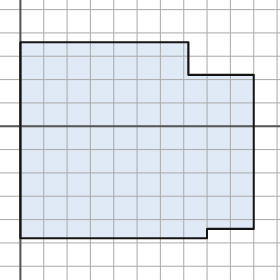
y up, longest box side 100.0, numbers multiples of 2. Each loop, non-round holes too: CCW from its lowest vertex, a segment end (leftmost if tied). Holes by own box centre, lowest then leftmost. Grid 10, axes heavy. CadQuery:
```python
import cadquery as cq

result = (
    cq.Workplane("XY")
    .moveTo(0.0, -48.0)
    .lineTo(80.0, -48.0)
    .lineTo(80.0, -44.0)
    .lineTo(100.0, -44.0)
    .lineTo(100.0, 22.0)
    .lineTo(72.0, 22.0)
    .lineTo(72.0, 36.0)
    .lineTo(0.0, 36.0)
    .close()
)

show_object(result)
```